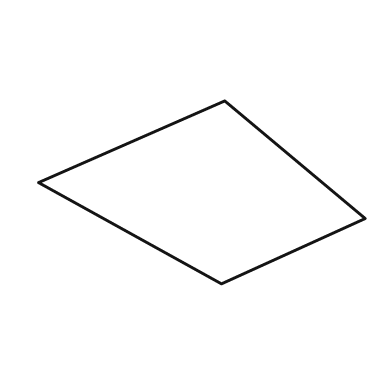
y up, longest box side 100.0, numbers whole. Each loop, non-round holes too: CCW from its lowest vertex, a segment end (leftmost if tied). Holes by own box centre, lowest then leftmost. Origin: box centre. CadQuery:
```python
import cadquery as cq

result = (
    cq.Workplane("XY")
    .moveTo(6.0, -28.0)
    .lineTo(50.0, -8.0)
    .lineTo(7.0, 28.0)
    .lineTo(-50.0, 3.0)
    .close()
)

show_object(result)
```